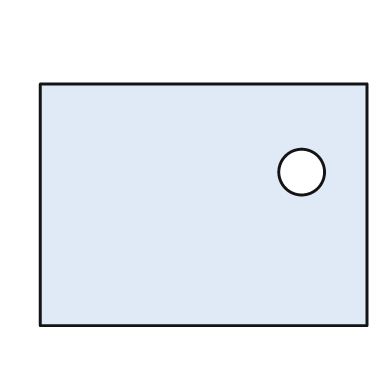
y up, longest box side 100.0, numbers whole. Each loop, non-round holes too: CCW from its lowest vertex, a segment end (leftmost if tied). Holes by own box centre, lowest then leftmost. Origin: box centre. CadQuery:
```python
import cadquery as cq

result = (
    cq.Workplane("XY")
    .moveTo(-50.0, -37.0)
    .lineTo(50.0, -37.0)
    .lineTo(50.0, 37.0)
    .lineTo(-50.0, 37.0)
    .close()
    .moveTo(30.0, 10.0)
    .circle(7.0)
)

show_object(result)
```